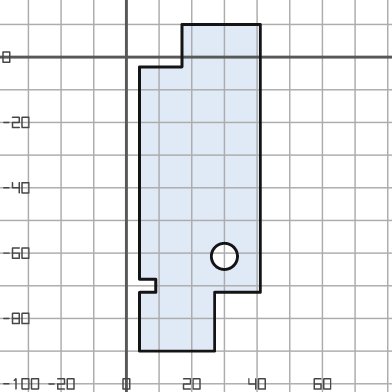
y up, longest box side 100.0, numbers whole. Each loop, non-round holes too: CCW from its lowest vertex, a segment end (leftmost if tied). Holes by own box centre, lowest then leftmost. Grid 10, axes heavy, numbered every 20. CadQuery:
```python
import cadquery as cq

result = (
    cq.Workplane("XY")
    .moveTo(4.0, -90.0)
    .lineTo(27.0, -90.0)
    .lineTo(27.0, -72.0)
    .lineTo(41.0, -72.0)
    .lineTo(41.0, 10.0)
    .lineTo(17.0, 10.0)
    .lineTo(17.0, -3.0)
    .lineTo(4.0, -3.0)
    .lineTo(4.0, -68.0)
    .lineTo(9.0, -68.0)
    .lineTo(9.0, -72.0)
    .lineTo(4.0, -72.0)
    .close()
    .moveTo(30.0, -61.0)
    .circle(4.0)
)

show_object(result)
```